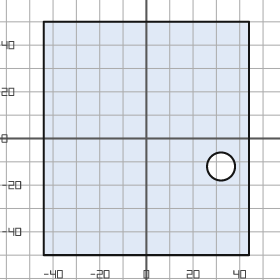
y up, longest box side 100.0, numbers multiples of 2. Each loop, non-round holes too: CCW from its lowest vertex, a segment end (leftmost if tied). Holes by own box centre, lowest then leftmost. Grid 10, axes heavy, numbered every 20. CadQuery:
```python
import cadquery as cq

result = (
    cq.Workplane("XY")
    .moveTo(-44.0, -50.0)
    .lineTo(44.0, -50.0)
    .lineTo(44.0, 50.0)
    .lineTo(-44.0, 50.0)
    .close()
    .moveTo(32.0, -12.0)
    .circle(6.0)
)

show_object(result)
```